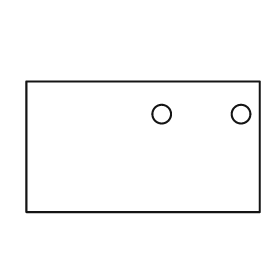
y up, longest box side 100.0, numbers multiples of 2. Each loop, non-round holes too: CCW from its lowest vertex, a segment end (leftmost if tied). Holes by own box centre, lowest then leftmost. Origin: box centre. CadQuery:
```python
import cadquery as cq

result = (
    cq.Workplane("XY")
    .moveTo(-50.0, -28.0)
    .lineTo(50.0, -28.0)
    .lineTo(50.0, 28.0)
    .lineTo(-50.0, 28.0)
    .close()
    .moveTo(8.0, 14.0)
    .circle(4.0)
    .moveTo(42.0, 14.0)
    .circle(4.0)
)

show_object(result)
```